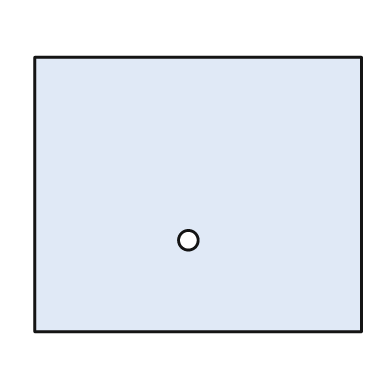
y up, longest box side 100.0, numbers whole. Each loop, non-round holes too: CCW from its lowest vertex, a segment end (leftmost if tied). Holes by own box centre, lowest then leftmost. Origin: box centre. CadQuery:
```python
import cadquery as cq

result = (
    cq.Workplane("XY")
    .moveTo(-50.0, -42.0)
    .lineTo(50.0, -42.0)
    .lineTo(50.0, 42.0)
    .lineTo(-50.0, 42.0)
    .close()
    .moveTo(-3.0, -14.0)
    .circle(3.0)
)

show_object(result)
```